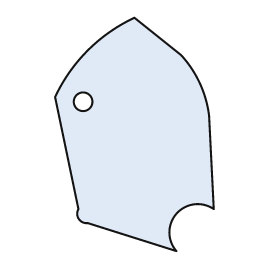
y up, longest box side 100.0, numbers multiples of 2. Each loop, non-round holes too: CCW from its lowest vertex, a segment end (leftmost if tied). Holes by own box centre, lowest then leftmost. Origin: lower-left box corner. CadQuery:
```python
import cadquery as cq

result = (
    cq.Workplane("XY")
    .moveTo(52.0, 0.0)
    .threePointArc((52.0, 16.0), (68.0, 18.0))
    .lineTo(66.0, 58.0)
    .threePointArc((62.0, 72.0), (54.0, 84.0))
    .lineTo(34.0, 100.0)
    .threePointArc((14.0, 86.0), (0.0, 66.0))
    .lineTo(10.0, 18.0)
    .threePointArc((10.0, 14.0), (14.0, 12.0))
    .close()
    .moveTo(12.0, 64.0)
    .circle(4.0)
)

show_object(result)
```